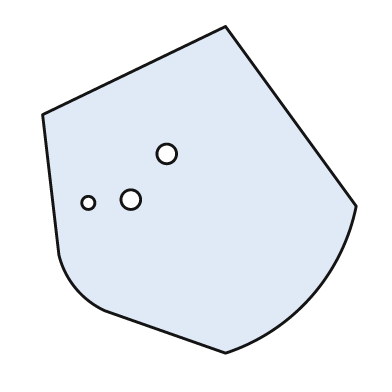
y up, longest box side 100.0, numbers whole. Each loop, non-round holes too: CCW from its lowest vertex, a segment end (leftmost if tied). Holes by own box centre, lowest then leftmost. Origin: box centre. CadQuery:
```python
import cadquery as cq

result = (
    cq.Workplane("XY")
    .moveTo(8.0, -50.0)
    .threePointArc((34.0, -33.0), (48.0, -5.0))
    .lineTo(8.0, 50.0)
    .lineTo(-48.0, 23.0)
    .lineTo(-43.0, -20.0)
    .threePointArc((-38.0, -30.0), (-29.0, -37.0))
    .close()
    .moveTo(-34.0, -4.0)
    .circle(2.0)
    .moveTo(-21.0, -3.0)
    .circle(3.0)
    .moveTo(-10.0, 11.0)
    .circle(3.0)
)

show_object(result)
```